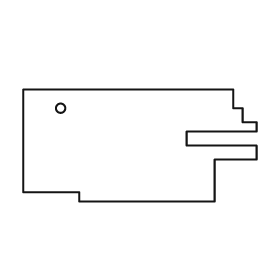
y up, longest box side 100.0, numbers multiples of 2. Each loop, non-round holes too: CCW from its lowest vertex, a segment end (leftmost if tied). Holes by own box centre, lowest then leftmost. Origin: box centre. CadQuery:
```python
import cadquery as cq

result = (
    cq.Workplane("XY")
    .moveTo(-26.0, -24.0)
    .lineTo(32.0, -24.0)
    .lineTo(32.0, -6.0)
    .lineTo(50.0, -6.0)
    .lineTo(50.0, 0.0)
    .lineTo(20.0, 0.0)
    .lineTo(20.0, 6.0)
    .lineTo(50.0, 6.0)
    .lineTo(50.0, 10.0)
    .lineTo(44.0, 10.0)
    .lineTo(44.0, 16.0)
    .lineTo(40.0, 16.0)
    .lineTo(40.0, 24.0)
    .lineTo(-50.0, 24.0)
    .lineTo(-50.0, -20.0)
    .lineTo(-26.0, -20.0)
    .close()
    .moveTo(-34.0, 16.0)
    .circle(2.0)
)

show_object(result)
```